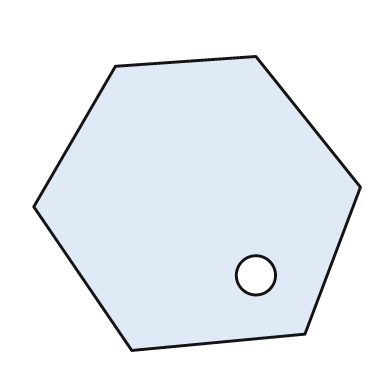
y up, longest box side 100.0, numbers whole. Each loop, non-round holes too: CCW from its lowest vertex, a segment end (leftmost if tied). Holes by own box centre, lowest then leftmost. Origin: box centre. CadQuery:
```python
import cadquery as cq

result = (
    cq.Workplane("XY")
    .moveTo(-20.0, -45.0)
    .lineTo(33.0, -40.0)
    .lineTo(50.0, 5.0)
    .lineTo(18.0, 45.0)
    .lineTo(-25.0, 42.0)
    .lineTo(-50.0, -1.0)
    .close()
    .moveTo(18.0, -22.0)
    .circle(6.0)
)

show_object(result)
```